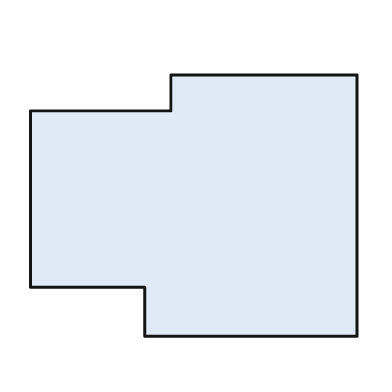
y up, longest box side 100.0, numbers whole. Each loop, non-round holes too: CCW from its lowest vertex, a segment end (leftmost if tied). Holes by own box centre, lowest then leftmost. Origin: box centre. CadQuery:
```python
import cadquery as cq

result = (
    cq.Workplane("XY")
    .moveTo(-15.0, -40.0)
    .lineTo(50.0, -40.0)
    .lineTo(50.0, 40.0)
    .lineTo(-7.0, 40.0)
    .lineTo(-7.0, 29.0)
    .lineTo(-50.0, 29.0)
    .lineTo(-50.0, -25.0)
    .lineTo(-15.0, -25.0)
    .close()
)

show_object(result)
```